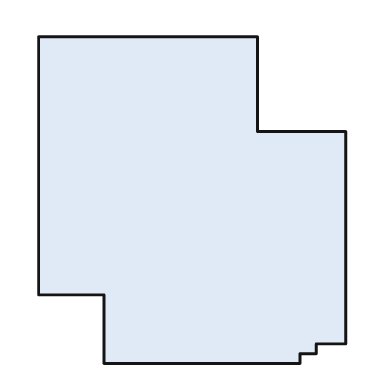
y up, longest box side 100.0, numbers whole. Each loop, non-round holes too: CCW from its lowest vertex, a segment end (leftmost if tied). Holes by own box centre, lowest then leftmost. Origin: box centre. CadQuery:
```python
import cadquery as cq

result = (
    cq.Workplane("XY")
    .moveTo(-27.0, -50.0)
    .lineTo(33.0, -50.0)
    .lineTo(33.0, -47.0)
    .lineTo(38.0, -47.0)
    .lineTo(38.0, -44.0)
    .lineTo(47.0, -44.0)
    .lineTo(47.0, 21.0)
    .lineTo(20.0, 21.0)
    .lineTo(20.0, 50.0)
    .lineTo(-47.0, 50.0)
    .lineTo(-47.0, -29.0)
    .lineTo(-27.0, -29.0)
    .close()
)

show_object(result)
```